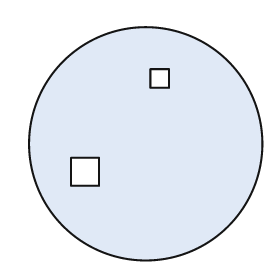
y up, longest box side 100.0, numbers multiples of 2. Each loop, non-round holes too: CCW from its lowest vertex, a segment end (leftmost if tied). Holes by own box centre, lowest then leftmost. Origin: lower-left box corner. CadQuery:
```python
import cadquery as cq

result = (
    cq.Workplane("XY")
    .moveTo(50.0, 50.0)
    .circle(50.0)
    .moveTo(18.0, 32.0)
    .lineTo(30.0, 32.0)
    .lineTo(30.0, 44.0)
    .lineTo(18.0, 44.0)
    .close()
    .moveTo(52.0, 74.0)
    .lineTo(60.0, 74.0)
    .lineTo(60.0, 82.0)
    .lineTo(52.0, 82.0)
    .close()
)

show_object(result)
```